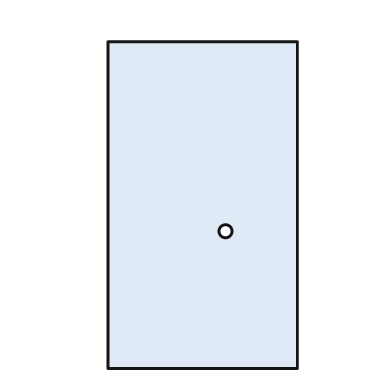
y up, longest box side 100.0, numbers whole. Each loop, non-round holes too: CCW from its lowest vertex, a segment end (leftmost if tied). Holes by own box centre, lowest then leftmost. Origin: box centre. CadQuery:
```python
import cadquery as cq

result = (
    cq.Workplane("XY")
    .moveTo(-29.0, -50.0)
    .lineTo(29.0, -50.0)
    .lineTo(29.0, 50.0)
    .lineTo(-29.0, 50.0)
    .close()
    .moveTo(7.0, -8.0)
    .circle(2.0)
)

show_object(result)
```